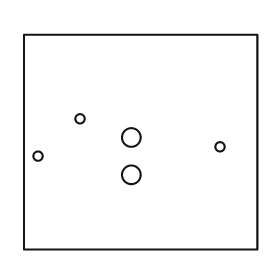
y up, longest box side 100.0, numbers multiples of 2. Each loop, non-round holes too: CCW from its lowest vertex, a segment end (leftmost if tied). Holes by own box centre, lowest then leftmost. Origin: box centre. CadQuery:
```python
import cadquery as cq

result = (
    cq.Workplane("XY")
    .moveTo(-50.0, -46.0)
    .lineTo(50.0, -46.0)
    .lineTo(50.0, 46.0)
    .lineTo(-50.0, 46.0)
    .close()
    .moveTo(-4.0, -14.0)
    .circle(4.0)
    .moveTo(-44.0, -6.0)
    .circle(2.0)
    .moveTo(34.0, -2.0)
    .circle(2.0)
    .moveTo(-4.0, 2.0)
    .circle(4.0)
    .moveTo(-26.0, 10.0)
    .circle(2.0)
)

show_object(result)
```